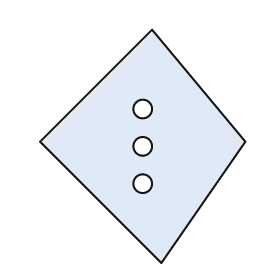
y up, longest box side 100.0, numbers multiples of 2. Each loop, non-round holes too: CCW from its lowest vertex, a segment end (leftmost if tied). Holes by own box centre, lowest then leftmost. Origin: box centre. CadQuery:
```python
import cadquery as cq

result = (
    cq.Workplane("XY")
    .moveTo(8.0, -50.0)
    .lineTo(44.0, 2.0)
    .lineTo(4.0, 50.0)
    .lineTo(-44.0, 2.0)
    .close()
    .moveTo(0.0, -16.0)
    .circle(4.0)
    .moveTo(0.0, 0.0)
    .circle(4.0)
    .moveTo(0.0, 16.0)
    .circle(4.0)
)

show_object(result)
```